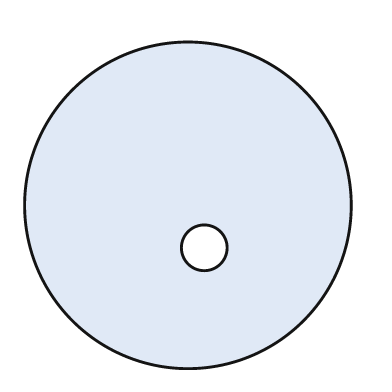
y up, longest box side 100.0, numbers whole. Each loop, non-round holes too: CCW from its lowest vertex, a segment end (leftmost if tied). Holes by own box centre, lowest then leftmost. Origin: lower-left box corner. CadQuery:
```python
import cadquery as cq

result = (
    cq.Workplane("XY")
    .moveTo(50.0, 50.0)
    .circle(50.0)
    .moveTo(55.0, 37.0)
    .circle(7.0)
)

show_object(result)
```